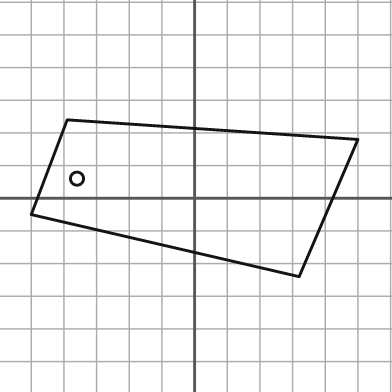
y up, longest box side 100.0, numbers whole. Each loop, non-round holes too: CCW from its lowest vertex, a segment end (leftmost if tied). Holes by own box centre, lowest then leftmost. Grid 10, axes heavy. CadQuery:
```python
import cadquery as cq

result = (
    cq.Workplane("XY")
    .moveTo(32.0, -24.0)
    .lineTo(50.0, 18.0)
    .lineTo(-39.0, 24.0)
    .lineTo(-50.0, -5.0)
    .close()
    .moveTo(-36.0, 6.0)
    .circle(2.0)
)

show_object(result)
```